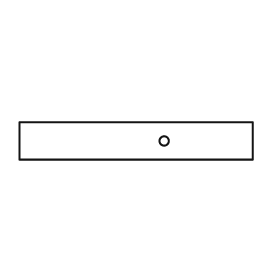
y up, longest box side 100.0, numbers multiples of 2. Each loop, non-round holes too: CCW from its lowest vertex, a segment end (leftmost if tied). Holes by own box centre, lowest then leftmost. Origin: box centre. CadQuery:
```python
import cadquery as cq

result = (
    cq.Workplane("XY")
    .moveTo(-50.0, -8.0)
    .lineTo(50.0, -8.0)
    .lineTo(50.0, 8.0)
    .lineTo(-50.0, 8.0)
    .close()
    .moveTo(12.0, 0.0)
    .circle(2.0)
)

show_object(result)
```